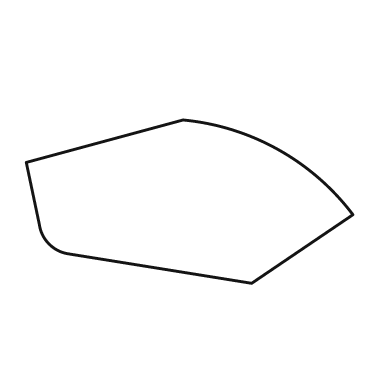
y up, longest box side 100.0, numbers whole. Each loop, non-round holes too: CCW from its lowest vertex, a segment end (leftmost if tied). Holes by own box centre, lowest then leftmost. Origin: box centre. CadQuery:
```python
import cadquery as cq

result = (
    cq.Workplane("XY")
    .moveTo(19.0, -25.0)
    .lineTo(50.0, -4.0)
    .threePointArc((27.0, 16.0), (-2.0, 25.0))
    .lineTo(-50.0, 12.0)
    .lineTo(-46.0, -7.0)
    .threePointArc((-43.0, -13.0), (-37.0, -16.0))
    .close()
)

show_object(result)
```